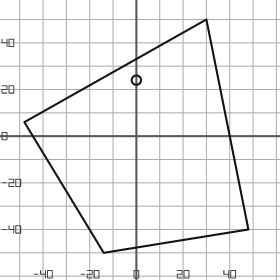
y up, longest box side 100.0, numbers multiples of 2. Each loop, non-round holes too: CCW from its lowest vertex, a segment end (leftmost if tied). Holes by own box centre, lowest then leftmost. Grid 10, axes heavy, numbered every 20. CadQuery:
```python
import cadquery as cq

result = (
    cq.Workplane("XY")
    .moveTo(-14.0, -50.0)
    .lineTo(48.0, -40.0)
    .lineTo(30.0, 50.0)
    .lineTo(-48.0, 6.0)
    .close()
    .moveTo(0.0, 24.0)
    .circle(2.0)
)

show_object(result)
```